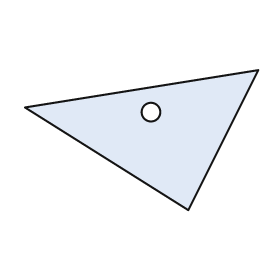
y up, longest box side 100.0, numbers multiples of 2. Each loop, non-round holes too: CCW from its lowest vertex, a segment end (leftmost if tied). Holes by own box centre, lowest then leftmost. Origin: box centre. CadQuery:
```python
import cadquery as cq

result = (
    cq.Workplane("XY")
    .moveTo(20.0, -30.0)
    .lineTo(50.0, 30.0)
    .lineTo(-50.0, 14.0)
    .close()
    .moveTo(4.0, 12.0)
    .circle(4.0)
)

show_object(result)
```